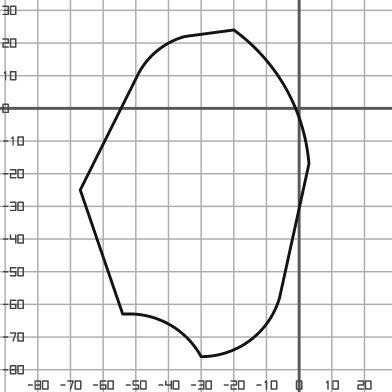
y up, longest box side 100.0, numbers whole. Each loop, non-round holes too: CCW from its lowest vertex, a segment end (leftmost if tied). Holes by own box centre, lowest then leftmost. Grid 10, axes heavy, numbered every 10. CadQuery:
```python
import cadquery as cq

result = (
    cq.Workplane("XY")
    .moveTo(-30.0, -76.0)
    .threePointArc((-15.0, -71.0), (-6.0, -58.0))
    .lineTo(3.0, -17.0)
    .threePointArc((-4.0, 6.0), (-20.0, 24.0))
    .lineTo(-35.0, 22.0)
    .threePointArc((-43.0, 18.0), (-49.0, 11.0))
    .lineTo(-67.0, -25.0)
    .lineTo(-54.0, -63.0)
    .threePointArc((-40.0, -66.0), (-30.0, -76.0))
    .close()
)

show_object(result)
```